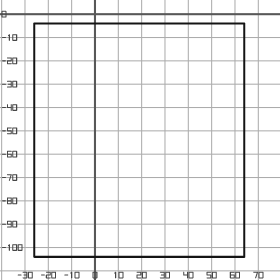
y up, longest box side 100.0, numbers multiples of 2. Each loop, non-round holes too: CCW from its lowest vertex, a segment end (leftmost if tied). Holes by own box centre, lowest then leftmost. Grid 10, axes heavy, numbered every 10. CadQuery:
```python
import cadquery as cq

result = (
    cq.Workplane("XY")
    .moveTo(-26.0, -104.0)
    .lineTo(64.0, -104.0)
    .lineTo(64.0, -4.0)
    .lineTo(-26.0, -4.0)
    .close()
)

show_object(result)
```